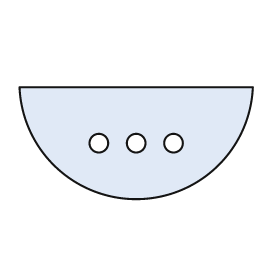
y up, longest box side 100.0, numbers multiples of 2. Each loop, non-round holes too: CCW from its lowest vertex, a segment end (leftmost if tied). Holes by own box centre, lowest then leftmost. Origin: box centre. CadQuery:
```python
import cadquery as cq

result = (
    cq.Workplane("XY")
    .moveTo(-50.0, 24.0)
    .threePointArc((0.0, -24.0), (50.0, 24.0))
    .close()
    .moveTo(-16.0, 0.0)
    .circle(4.0)
    .moveTo(0.0, 0.0)
    .circle(4.0)
    .moveTo(16.0, 0.0)
    .circle(4.0)
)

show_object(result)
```